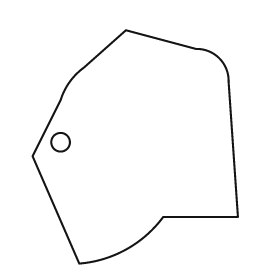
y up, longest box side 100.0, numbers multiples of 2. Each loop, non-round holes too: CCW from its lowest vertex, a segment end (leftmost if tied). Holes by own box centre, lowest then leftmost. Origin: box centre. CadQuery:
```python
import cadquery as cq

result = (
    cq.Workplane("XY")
    .moveTo(-24.0, -50.0)
    .threePointArc((-4.0, -44.0), (12.0, -30.0))
    .lineTo(44.0, -30.0)
    .lineTo(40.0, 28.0)
    .threePointArc((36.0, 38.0), (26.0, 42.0))
    .lineTo(-4.0, 50.0)
    .lineTo(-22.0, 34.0)
    .threePointArc((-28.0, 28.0), (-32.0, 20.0))
    .lineTo(-44.0, -4.0)
    .close()
    .moveTo(-32.0, 2.0)
    .circle(4.0)
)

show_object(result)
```